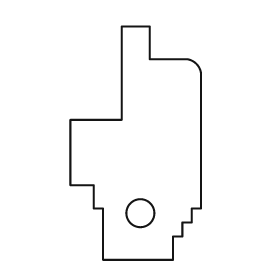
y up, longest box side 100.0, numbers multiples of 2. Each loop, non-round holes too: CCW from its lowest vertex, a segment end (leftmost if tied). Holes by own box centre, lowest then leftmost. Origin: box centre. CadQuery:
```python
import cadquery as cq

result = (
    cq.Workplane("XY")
    .moveTo(-14.0, -50.0)
    .lineTo(16.0, -50.0)
    .lineTo(16.0, -40.0)
    .lineTo(20.0, -40.0)
    .lineTo(20.0, -34.0)
    .lineTo(24.0, -34.0)
    .lineTo(24.0, -28.0)
    .lineTo(28.0, -28.0)
    .lineTo(28.0, 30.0)
    .threePointArc((26.0, 34.0), (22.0, 36.0))
    .lineTo(6.0, 36.0)
    .lineTo(6.0, 50.0)
    .lineTo(-6.0, 50.0)
    .lineTo(-6.0, 10.0)
    .lineTo(-28.0, 10.0)
    .lineTo(-28.0, -18.0)
    .lineTo(-18.0, -18.0)
    .lineTo(-18.0, -28.0)
    .lineTo(-14.0, -28.0)
    .close()
    .moveTo(2.0, -30.0)
    .circle(6.0)
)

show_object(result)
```